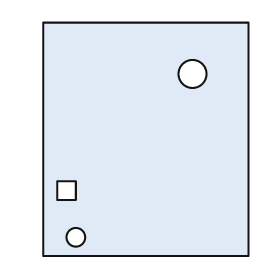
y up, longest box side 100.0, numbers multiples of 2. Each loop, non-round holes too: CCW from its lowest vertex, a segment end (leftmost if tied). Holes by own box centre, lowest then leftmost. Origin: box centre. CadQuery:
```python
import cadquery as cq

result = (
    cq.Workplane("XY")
    .moveTo(-44.0, -50.0)
    .lineTo(44.0, -50.0)
    .lineTo(44.0, 50.0)
    .lineTo(-44.0, 50.0)
    .close()
    .moveTo(-30.0, -42.0)
    .circle(4.0)
    .moveTo(-38.0, -26.0)
    .lineTo(-30.0, -26.0)
    .lineTo(-30.0, -18.0)
    .lineTo(-38.0, -18.0)
    .close()
    .moveTo(20.0, 28.0)
    .circle(6.0)
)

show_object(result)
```